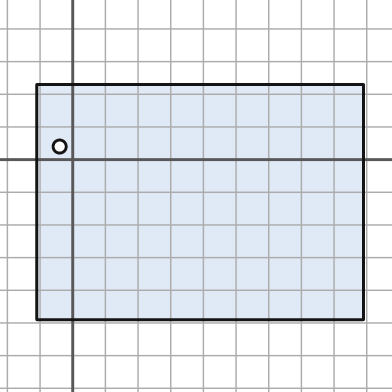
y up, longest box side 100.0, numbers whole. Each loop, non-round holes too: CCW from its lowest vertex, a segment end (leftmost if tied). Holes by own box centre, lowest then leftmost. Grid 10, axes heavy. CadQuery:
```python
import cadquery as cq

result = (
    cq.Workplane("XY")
    .moveTo(-11.0, -49.0)
    .lineTo(89.0, -49.0)
    .lineTo(89.0, 23.0)
    .lineTo(-11.0, 23.0)
    .close()
    .moveTo(-4.0, 4.0)
    .circle(2.0)
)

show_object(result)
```